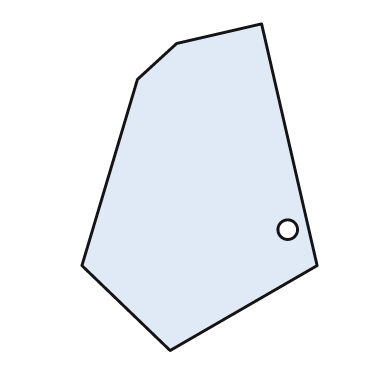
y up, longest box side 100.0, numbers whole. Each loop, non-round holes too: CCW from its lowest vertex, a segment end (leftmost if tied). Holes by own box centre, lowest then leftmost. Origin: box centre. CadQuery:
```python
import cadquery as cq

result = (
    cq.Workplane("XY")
    .moveTo(-9.0, -50.0)
    .lineTo(36.0, -24.0)
    .lineTo(19.0, 50.0)
    .lineTo(-7.0, 44.0)
    .lineTo(-19.0, 33.0)
    .lineTo(-36.0, -24.0)
    .close()
    .moveTo(27.0, -13.0)
    .circle(3.0)
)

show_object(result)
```